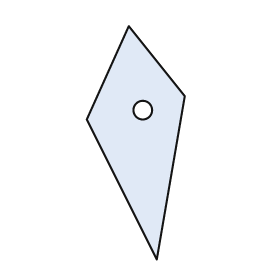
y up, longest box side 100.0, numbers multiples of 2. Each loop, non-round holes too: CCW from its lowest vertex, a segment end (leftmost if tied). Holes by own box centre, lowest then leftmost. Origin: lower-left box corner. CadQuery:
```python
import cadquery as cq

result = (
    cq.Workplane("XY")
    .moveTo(30.0, 0.0)
    .lineTo(42.0, 70.0)
    .lineTo(18.0, 100.0)
    .lineTo(0.0, 60.0)
    .close()
    .moveTo(24.0, 64.0)
    .circle(4.0)
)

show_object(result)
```